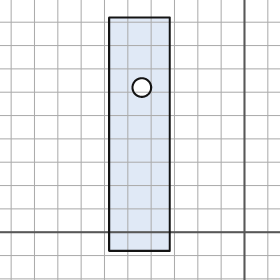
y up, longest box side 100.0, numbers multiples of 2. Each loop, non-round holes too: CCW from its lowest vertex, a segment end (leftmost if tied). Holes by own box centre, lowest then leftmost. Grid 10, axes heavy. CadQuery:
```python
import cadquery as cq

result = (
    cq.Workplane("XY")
    .moveTo(-58.0, -8.0)
    .lineTo(-32.0, -8.0)
    .lineTo(-32.0, 92.0)
    .lineTo(-58.0, 92.0)
    .close()
    .moveTo(-44.0, 62.0)
    .circle(4.0)
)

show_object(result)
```